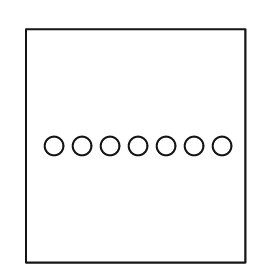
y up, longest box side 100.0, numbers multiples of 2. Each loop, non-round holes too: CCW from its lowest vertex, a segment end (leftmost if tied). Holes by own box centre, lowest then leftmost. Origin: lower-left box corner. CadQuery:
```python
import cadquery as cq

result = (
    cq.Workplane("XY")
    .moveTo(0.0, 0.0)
    .lineTo(94.0, 0.0)
    .lineTo(94.0, 100.0)
    .lineTo(0.0, 100.0)
    .close()
    .moveTo(12.0, 50.0)
    .circle(4.0)
    .moveTo(24.0, 50.0)
    .circle(4.0)
    .moveTo(36.0, 50.0)
    .circle(4.0)
    .moveTo(48.0, 50.0)
    .circle(4.0)
    .moveTo(60.0, 50.0)
    .circle(4.0)
    .moveTo(72.0, 50.0)
    .circle(4.0)
    .moveTo(84.0, 50.0)
    .circle(4.0)
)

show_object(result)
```